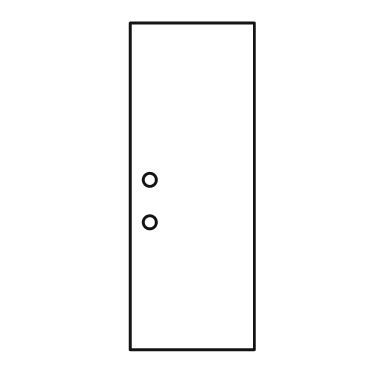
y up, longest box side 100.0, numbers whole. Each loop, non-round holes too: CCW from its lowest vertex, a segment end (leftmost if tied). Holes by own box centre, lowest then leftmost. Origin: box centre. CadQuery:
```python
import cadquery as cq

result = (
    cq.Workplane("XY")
    .moveTo(-19.0, -50.0)
    .lineTo(19.0, -50.0)
    .lineTo(19.0, 50.0)
    .lineTo(-19.0, 50.0)
    .close()
    .moveTo(-13.0, -11.0)
    .circle(2.0)
    .moveTo(-13.0, 2.0)
    .circle(2.0)
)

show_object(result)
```